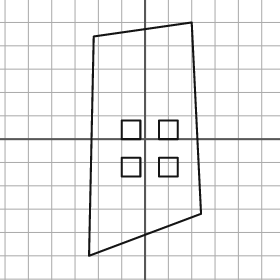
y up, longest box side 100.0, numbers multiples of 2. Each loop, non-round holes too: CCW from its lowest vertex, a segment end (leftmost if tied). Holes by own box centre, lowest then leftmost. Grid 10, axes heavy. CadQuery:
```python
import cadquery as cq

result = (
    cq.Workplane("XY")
    .moveTo(-24.0, -50.0)
    .lineTo(24.0, -32.0)
    .lineTo(20.0, 50.0)
    .lineTo(-22.0, 44.0)
    .close()
    .moveTo(-10.0, -16.0)
    .lineTo(-2.0, -16.0)
    .lineTo(-2.0, -8.0)
    .lineTo(-10.0, -8.0)
    .close()
    .moveTo(6.0, -16.0)
    .lineTo(14.0, -16.0)
    .lineTo(14.0, -8.0)
    .lineTo(6.0, -8.0)
    .close()
    .moveTo(-10.0, 0.0)
    .lineTo(-2.0, 0.0)
    .lineTo(-2.0, 8.0)
    .lineTo(-10.0, 8.0)
    .close()
    .moveTo(6.0, 0.0)
    .lineTo(14.0, 0.0)
    .lineTo(14.0, 8.0)
    .lineTo(6.0, 8.0)
    .close()
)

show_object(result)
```